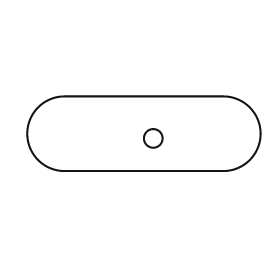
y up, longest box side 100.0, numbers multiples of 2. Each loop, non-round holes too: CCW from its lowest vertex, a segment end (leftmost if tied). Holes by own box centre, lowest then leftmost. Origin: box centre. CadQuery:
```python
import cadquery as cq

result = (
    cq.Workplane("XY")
    .moveTo(-34.0, -16.0)
    .lineTo(34.0, -16.0)
    .threePointArc((50.0, 0.0), (34.0, 16.0))
    .lineTo(-34.0, 16.0)
    .threePointArc((-50.0, 0.0), (-34.0, -16.0))
    .close()
    .moveTo(4.0, -2.0)
    .circle(4.0)
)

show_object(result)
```